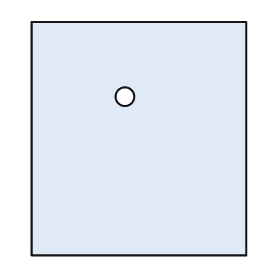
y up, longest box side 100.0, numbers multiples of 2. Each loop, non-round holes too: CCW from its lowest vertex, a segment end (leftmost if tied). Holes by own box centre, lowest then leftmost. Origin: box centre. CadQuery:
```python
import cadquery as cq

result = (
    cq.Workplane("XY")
    .moveTo(-46.0, -50.0)
    .lineTo(46.0, -50.0)
    .lineTo(46.0, 50.0)
    .lineTo(-46.0, 50.0)
    .close()
    .moveTo(-6.0, 18.0)
    .circle(4.0)
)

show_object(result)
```